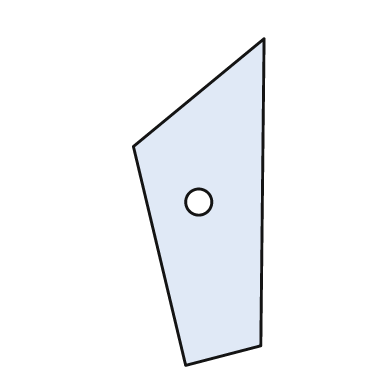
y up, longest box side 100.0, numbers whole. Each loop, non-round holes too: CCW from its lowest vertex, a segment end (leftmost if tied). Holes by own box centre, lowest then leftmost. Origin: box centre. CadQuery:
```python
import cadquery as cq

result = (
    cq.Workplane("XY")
    .moveTo(-4.0, -50.0)
    .lineTo(19.0, -44.0)
    .lineTo(20.0, 50.0)
    .lineTo(-20.0, 17.0)
    .close()
    .moveTo(0.0, 0.0)
    .circle(4.0)
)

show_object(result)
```